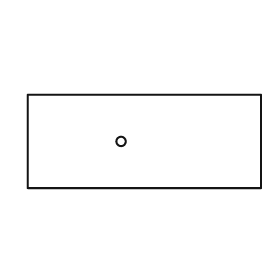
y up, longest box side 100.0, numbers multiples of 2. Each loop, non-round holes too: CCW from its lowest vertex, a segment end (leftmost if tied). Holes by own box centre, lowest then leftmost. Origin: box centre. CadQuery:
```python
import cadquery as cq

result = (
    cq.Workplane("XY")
    .moveTo(-50.0, -20.0)
    .lineTo(50.0, -20.0)
    .lineTo(50.0, 20.0)
    .lineTo(-50.0, 20.0)
    .close()
    .moveTo(-10.0, 0.0)
    .circle(2.0)
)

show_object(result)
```